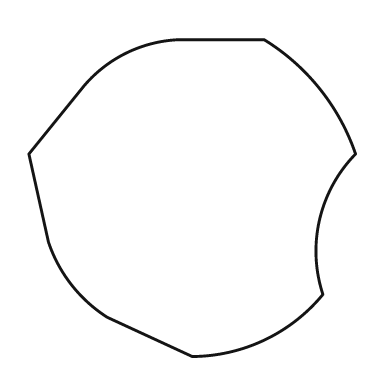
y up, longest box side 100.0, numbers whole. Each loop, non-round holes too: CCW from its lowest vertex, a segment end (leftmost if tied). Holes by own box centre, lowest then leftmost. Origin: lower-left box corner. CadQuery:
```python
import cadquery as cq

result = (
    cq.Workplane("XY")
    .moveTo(50.0, 0.0)
    .threePointArc((72.0, 5.0), (90.0, 19.0))
    .threePointArc((89.0, 42.0), (100.0, 62.0))
    .threePointArc((89.0, 82.0), (72.0, 97.0))
    .lineTo(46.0, 97.0)
    .threePointArc((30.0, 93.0), (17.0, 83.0))
    .lineTo(0.0, 62.0)
    .lineTo(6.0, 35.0)
    .threePointArc((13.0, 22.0), (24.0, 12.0))
    .close()
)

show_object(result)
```